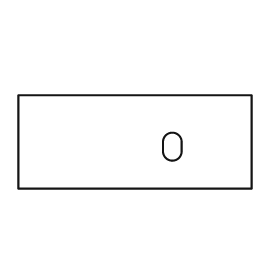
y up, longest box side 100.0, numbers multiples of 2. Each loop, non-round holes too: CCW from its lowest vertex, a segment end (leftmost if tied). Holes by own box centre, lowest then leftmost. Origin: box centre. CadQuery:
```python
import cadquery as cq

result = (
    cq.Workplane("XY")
    .moveTo(-50.0, -20.0)
    .lineTo(50.0, -20.0)
    .lineTo(50.0, 20.0)
    .lineTo(-50.0, 20.0)
    .close()
    .moveTo(12.0, -4.0)
    .threePointArc((16.0, -8.0), (20.0, -4.0))
    .lineTo(20.0, 0.0)
    .threePointArc((16.0, 4.0), (12.0, 0.0))
    .close()
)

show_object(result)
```